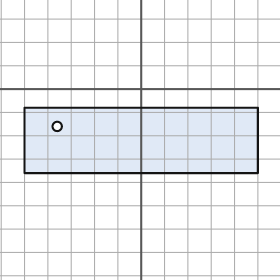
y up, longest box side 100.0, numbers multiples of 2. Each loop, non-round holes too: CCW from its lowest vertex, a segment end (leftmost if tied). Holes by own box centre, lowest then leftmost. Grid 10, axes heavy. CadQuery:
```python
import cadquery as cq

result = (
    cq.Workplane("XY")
    .moveTo(-50.0, -36.0)
    .lineTo(50.0, -36.0)
    .lineTo(50.0, -8.0)
    .lineTo(-50.0, -8.0)
    .close()
    .moveTo(-36.0, -16.0)
    .circle(2.0)
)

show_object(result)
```